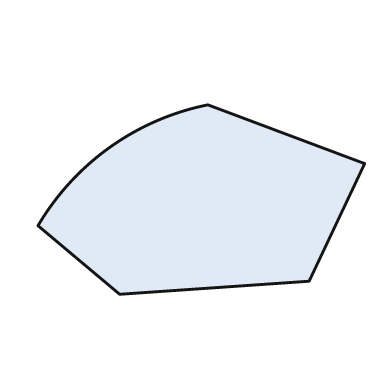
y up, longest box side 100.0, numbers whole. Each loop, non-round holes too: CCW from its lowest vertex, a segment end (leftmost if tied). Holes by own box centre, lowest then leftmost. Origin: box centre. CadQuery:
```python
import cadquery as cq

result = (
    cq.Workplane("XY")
    .moveTo(-25.0, -29.0)
    .lineTo(33.0, -25.0)
    .lineTo(50.0, 11.0)
    .lineTo(2.0, 29.0)
    .threePointArc((-28.0, 16.0), (-50.0, -8.0))
    .close()
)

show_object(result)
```